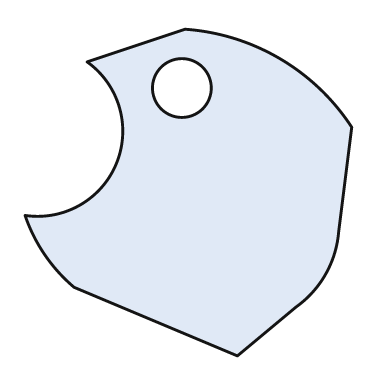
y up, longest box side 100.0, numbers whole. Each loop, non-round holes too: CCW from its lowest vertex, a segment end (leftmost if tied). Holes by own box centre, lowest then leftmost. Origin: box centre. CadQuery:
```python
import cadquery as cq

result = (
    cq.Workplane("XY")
    .moveTo(15.0, -50.0)
    .lineTo(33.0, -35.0)
    .threePointArc((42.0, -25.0), (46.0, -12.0))
    .lineTo(50.0, 20.0)
    .threePointArc((28.0, 41.0), (-1.0, 50.0))
    .lineTo(-31.0, 40.0)
    .threePointArc((-22.0, 9.0), (-50.0, -7.0))
    .threePointArc((-44.0, -19.0), (-35.0, -29.0))
    .close()
    .moveTo(-2.0, 32.0)
    .circle(9.0)
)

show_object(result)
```